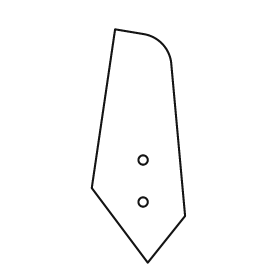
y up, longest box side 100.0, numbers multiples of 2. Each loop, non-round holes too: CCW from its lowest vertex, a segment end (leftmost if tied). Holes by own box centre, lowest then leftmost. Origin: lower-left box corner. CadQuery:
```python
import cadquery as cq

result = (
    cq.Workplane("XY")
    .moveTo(24.0, 0.0)
    .lineTo(40.0, 20.0)
    .lineTo(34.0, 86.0)
    .threePointArc((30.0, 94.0), (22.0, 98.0))
    .lineTo(10.0, 100.0)
    .lineTo(0.0, 32.0)
    .close()
    .moveTo(22.0, 26.0)
    .circle(2.0)
    .moveTo(22.0, 44.0)
    .circle(2.0)
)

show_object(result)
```